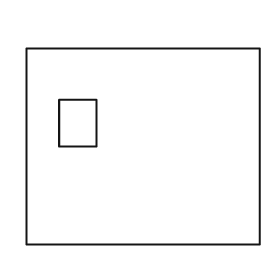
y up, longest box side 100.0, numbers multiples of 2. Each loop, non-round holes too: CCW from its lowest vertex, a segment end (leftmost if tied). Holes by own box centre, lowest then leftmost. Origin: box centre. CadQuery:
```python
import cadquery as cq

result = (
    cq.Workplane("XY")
    .moveTo(-50.0, -42.0)
    .lineTo(50.0, -42.0)
    .lineTo(50.0, 42.0)
    .lineTo(-50.0, 42.0)
    .close()
    .moveTo(-36.0, 0.0)
    .lineTo(-20.0, 0.0)
    .lineTo(-20.0, 20.0)
    .lineTo(-36.0, 20.0)
    .close()
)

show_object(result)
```